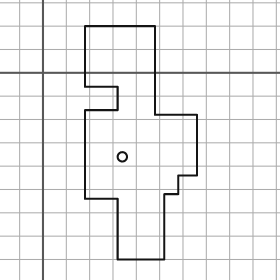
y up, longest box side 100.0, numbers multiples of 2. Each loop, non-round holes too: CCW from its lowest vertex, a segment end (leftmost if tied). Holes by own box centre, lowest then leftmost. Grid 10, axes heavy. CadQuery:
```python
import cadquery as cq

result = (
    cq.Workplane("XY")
    .moveTo(32.0, -80.0)
    .lineTo(52.0, -80.0)
    .lineTo(52.0, -52.0)
    .lineTo(58.0, -52.0)
    .lineTo(58.0, -44.0)
    .lineTo(66.0, -44.0)
    .lineTo(66.0, -18.0)
    .lineTo(48.0, -18.0)
    .lineTo(48.0, 20.0)
    .lineTo(18.0, 20.0)
    .lineTo(18.0, -6.0)
    .lineTo(32.0, -6.0)
    .lineTo(32.0, -16.0)
    .lineTo(18.0, -16.0)
    .lineTo(18.0, -54.0)
    .lineTo(32.0, -54.0)
    .close()
    .moveTo(34.0, -36.0)
    .circle(2.0)
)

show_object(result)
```